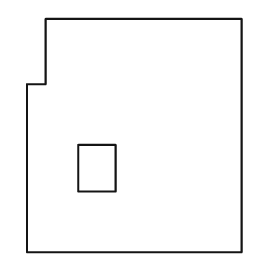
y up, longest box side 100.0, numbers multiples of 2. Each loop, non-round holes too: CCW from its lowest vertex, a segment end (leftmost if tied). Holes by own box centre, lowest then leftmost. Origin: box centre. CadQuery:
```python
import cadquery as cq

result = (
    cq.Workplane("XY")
    .moveTo(-46.0, -50.0)
    .lineTo(46.0, -50.0)
    .lineTo(46.0, 50.0)
    .lineTo(-38.0, 50.0)
    .lineTo(-38.0, 22.0)
    .lineTo(-46.0, 22.0)
    .close()
    .moveTo(-24.0, -24.0)
    .lineTo(-8.0, -24.0)
    .lineTo(-8.0, -4.0)
    .lineTo(-24.0, -4.0)
    .close()
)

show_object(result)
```